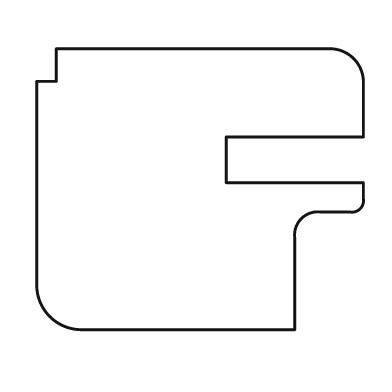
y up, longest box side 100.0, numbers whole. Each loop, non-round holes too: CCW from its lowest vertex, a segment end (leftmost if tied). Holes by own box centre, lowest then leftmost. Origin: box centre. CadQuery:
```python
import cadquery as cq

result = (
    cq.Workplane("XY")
    .moveTo(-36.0, -43.0)
    .lineTo(29.0, -43.0)
    .lineTo(29.0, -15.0)
    .threePointArc((31.0, -9.0), (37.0, -7.0))
    .lineTo(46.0, -7.0)
    .threePointArc((49.0, -6.0), (50.0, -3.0))
    .lineTo(50.0, 2.0)
    .lineTo(8.0, 2.0)
    .lineTo(8.0, 16.0)
    .lineTo(50.0, 16.0)
    .lineTo(50.0, 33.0)
    .threePointArc((47.0, 40.0), (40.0, 43.0))
    .lineTo(-44.0, 43.0)
    .lineTo(-44.0, 33.0)
    .lineTo(-50.0, 33.0)
    .lineTo(-50.0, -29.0)
    .threePointArc((-46.0, -39.0), (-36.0, -43.0))
    .close()
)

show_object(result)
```